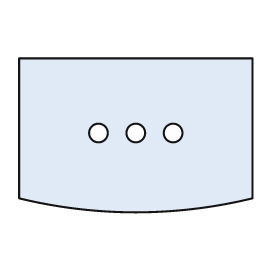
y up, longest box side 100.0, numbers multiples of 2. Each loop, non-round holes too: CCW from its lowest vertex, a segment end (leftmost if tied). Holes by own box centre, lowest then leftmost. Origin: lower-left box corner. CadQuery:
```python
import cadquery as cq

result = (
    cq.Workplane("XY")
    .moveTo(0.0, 6.0)
    .threePointArc((50.0, 0.0), (100.0, 6.0))
    .lineTo(100.0, 66.0)
    .lineTo(0.0, 66.0)
    .close()
    .moveTo(34.0, 34.0)
    .circle(4.0)
    .moveTo(50.0, 34.0)
    .circle(4.0)
    .moveTo(66.0, 34.0)
    .circle(4.0)
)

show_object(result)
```